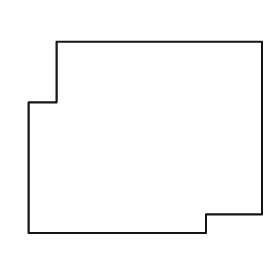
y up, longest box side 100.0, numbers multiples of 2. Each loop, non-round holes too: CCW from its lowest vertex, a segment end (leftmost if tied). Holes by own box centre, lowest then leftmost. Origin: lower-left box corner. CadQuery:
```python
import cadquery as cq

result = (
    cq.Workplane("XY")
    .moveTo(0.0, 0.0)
    .lineTo(76.0, 0.0)
    .lineTo(76.0, 8.0)
    .lineTo(100.0, 8.0)
    .lineTo(100.0, 82.0)
    .lineTo(12.0, 82.0)
    .lineTo(12.0, 56.0)
    .lineTo(0.0, 56.0)
    .close()
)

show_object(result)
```